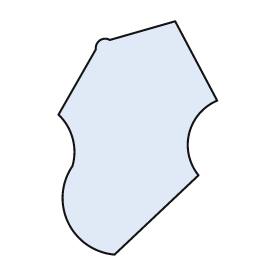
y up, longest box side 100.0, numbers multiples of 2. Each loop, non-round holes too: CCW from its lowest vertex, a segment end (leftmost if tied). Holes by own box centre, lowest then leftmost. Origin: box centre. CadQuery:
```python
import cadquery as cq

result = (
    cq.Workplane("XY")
    .moveTo(-10.0, -50.0)
    .lineTo(26.0, -16.0)
    .threePointArc((22.0, 2.0), (34.0, 16.0))
    .lineTo(16.0, 50.0)
    .lineTo(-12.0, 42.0)
    .threePointArc((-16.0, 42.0), (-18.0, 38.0))
    .lineTo(-34.0, 10.0)
    .threePointArc((-28.0, 0.0), (-28.0, -12.0))
    .threePointArc((-30.0, -36.0), (-10.0, -50.0))
    .close()
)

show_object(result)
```